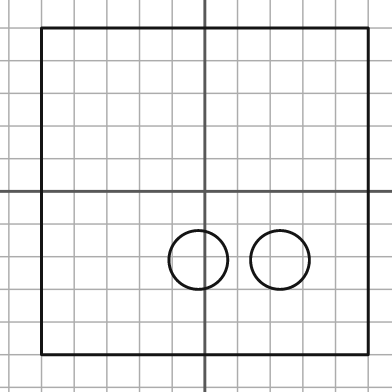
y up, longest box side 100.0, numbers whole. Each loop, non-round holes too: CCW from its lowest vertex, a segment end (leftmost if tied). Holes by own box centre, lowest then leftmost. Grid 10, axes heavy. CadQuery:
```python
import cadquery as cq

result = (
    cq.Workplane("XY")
    .moveTo(-50.0, -50.0)
    .lineTo(50.0, -50.0)
    .lineTo(50.0, 50.0)
    .lineTo(-50.0, 50.0)
    .close()
    .moveTo(-2.0, -21.0)
    .circle(9.0)
    .moveTo(23.0, -21.0)
    .circle(9.0)
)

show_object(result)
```